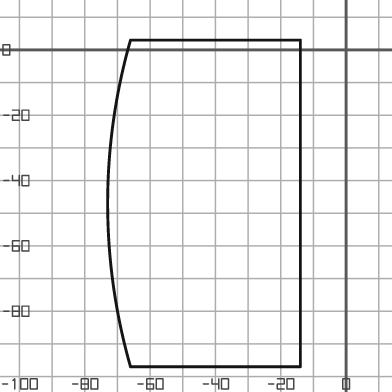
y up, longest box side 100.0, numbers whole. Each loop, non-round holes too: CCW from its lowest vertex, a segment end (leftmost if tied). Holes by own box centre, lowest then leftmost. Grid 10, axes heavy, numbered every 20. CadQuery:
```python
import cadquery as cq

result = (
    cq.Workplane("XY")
    .moveTo(-66.0, -97.0)
    .lineTo(-14.0, -97.0)
    .lineTo(-14.0, 3.0)
    .lineTo(-66.0, 3.0)
    .threePointArc((-73.0, -47.0), (-66.0, -97.0))
    .close()
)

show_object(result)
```